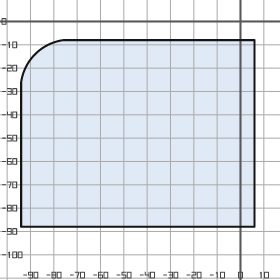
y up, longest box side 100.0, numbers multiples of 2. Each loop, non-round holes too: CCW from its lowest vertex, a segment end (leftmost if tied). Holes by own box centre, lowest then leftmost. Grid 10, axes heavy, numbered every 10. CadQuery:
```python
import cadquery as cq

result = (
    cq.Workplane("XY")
    .moveTo(-94.0, -88.0)
    .lineTo(6.0, -88.0)
    .lineTo(6.0, -8.0)
    .lineTo(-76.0, -8.0)
    .threePointArc((-88.0, -14.0), (-94.0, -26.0))
    .close()
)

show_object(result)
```